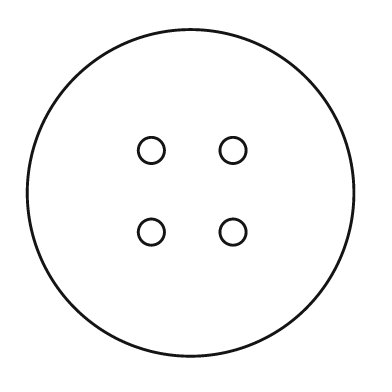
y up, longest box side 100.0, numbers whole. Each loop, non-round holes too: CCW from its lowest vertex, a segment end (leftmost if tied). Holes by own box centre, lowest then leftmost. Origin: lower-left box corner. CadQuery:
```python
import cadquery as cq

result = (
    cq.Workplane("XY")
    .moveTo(50.0, 50.0)
    .circle(50.0)
    .moveTo(38.0, 38.0)
    .circle(4.0)
    .moveTo(63.0, 38.0)
    .circle(4.0)
    .moveTo(38.0, 63.0)
    .circle(4.0)
    .moveTo(63.0, 63.0)
    .circle(4.0)
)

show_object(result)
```